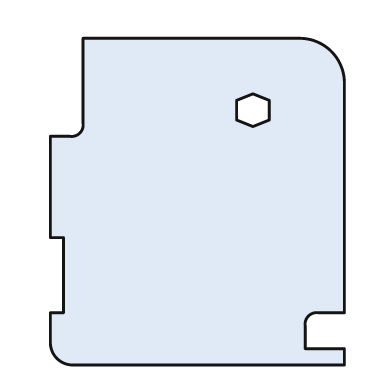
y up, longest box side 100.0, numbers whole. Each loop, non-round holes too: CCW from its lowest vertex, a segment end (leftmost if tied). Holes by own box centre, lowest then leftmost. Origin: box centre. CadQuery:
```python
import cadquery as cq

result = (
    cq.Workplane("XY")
    .moveTo(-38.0, -50.0)
    .lineTo(45.0, -50.0)
    .lineTo(45.0, -45.0)
    .lineTo(33.0, -45.0)
    .lineTo(33.0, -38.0)
    .threePointArc((34.0, -35.0), (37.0, -34.0))
    .lineTo(45.0, -34.0)
    .lineTo(45.0, 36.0)
    .threePointArc((41.0, 46.0), (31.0, 50.0))
    .lineTo(-35.0, 50.0)
    .lineTo(-35.0, 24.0)
    .threePointArc((-36.0, 21.0), (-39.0, 20.0))
    .lineTo(-45.0, 20.0)
    .lineTo(-45.0, -11.0)
    .lineTo(-41.0, -11.0)
    .lineTo(-41.0, -34.0)
    .lineTo(-45.0, -34.0)
    .lineTo(-45.0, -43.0)
    .threePointArc((-43.0, -48.0), (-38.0, -50.0))
    .close()
    .moveTo(17.0, 23.0)
    .lineTo(22.0, 25.0)
    .lineTo(22.0, 31.0)
    .lineTo(17.0, 33.0)
    .lineTo(12.0, 31.0)
    .lineTo(12.0, 25.0)
    .close()
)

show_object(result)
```